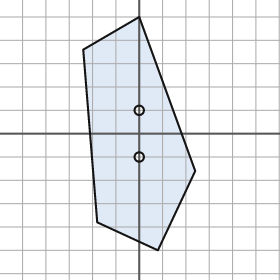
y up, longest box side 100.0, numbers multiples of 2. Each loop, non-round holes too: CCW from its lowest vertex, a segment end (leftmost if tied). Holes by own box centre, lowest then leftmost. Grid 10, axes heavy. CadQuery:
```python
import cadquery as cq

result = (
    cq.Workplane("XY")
    .moveTo(8.0, -50.0)
    .lineTo(24.0, -16.0)
    .lineTo(0.0, 50.0)
    .lineTo(-24.0, 36.0)
    .lineTo(-18.0, -38.0)
    .close()
    .moveTo(0.0, -10.0)
    .circle(2.0)
    .moveTo(0.0, 10.0)
    .circle(2.0)
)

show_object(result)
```